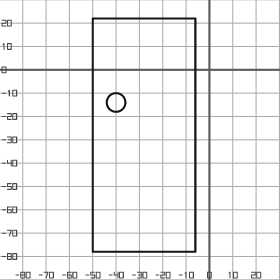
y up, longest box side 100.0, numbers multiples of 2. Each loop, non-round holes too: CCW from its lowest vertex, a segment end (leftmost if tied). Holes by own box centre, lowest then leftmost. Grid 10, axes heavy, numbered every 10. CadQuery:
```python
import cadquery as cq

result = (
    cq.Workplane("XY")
    .moveTo(-50.0, -78.0)
    .lineTo(-6.0, -78.0)
    .lineTo(-6.0, 22.0)
    .lineTo(-50.0, 22.0)
    .close()
    .moveTo(-40.0, -14.0)
    .circle(4.0)
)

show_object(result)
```